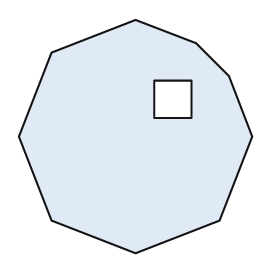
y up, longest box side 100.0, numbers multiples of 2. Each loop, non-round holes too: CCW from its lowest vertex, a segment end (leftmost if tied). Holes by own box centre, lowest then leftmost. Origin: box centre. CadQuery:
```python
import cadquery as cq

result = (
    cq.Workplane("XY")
    .moveTo(0.0, -50.0)
    .lineTo(36.0, -36.0)
    .lineTo(50.0, 0.0)
    .lineTo(40.0, 26.0)
    .lineTo(26.0, 40.0)
    .lineTo(0.0, 50.0)
    .lineTo(-36.0, 36.0)
    .lineTo(-50.0, 0.0)
    .lineTo(-36.0, -36.0)
    .close()
    .moveTo(8.0, 8.0)
    .lineTo(24.0, 8.0)
    .lineTo(24.0, 24.0)
    .lineTo(8.0, 24.0)
    .close()
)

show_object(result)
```